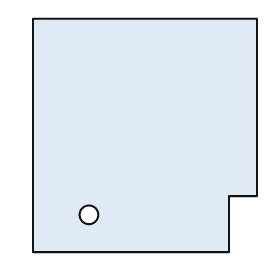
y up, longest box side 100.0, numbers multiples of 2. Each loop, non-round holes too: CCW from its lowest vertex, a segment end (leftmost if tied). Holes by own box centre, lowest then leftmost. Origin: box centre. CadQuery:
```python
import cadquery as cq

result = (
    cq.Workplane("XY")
    .moveTo(-48.0, -50.0)
    .lineTo(36.0, -50.0)
    .lineTo(36.0, -26.0)
    .lineTo(48.0, -26.0)
    .lineTo(48.0, 50.0)
    .lineTo(-48.0, 50.0)
    .close()
    .moveTo(-24.0, -34.0)
    .circle(4.0)
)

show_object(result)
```